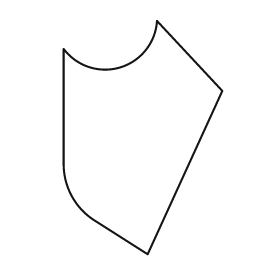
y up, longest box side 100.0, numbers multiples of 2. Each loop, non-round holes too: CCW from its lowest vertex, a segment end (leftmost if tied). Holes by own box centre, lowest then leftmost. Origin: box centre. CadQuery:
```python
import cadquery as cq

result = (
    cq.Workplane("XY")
    .moveTo(2.0, -50.0)
    .lineTo(34.0, 20.0)
    .lineTo(6.0, 50.0)
    .threePointArc((-10.0, 30.0), (-34.0, 38.0))
    .lineTo(-34.0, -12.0)
    .threePointArc((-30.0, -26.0), (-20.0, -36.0))
    .close()
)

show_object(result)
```